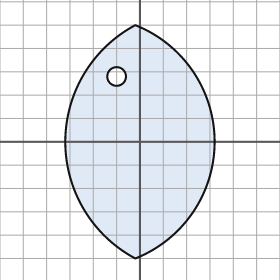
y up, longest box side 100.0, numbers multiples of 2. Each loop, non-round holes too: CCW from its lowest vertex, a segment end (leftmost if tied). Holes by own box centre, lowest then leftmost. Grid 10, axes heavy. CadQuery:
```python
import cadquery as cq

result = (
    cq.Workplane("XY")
    .moveTo(-2.0, -50.0)
    .threePointArc((32.0, 0.0), (-2.0, 50.0))
    .threePointArc((-32.0, 0.0), (-2.0, -50.0))
    .close()
    .moveTo(-10.0, 28.0)
    .circle(4.0)
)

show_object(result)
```